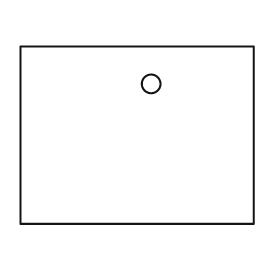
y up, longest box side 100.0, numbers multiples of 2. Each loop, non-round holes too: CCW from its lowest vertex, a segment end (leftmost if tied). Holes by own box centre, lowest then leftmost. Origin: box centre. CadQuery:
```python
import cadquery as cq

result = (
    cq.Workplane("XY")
    .moveTo(-50.0, -38.0)
    .lineTo(50.0, -38.0)
    .lineTo(50.0, 38.0)
    .lineTo(-50.0, 38.0)
    .close()
    .moveTo(6.0, 22.0)
    .circle(4.0)
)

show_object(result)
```